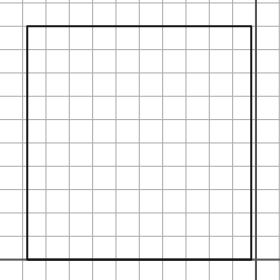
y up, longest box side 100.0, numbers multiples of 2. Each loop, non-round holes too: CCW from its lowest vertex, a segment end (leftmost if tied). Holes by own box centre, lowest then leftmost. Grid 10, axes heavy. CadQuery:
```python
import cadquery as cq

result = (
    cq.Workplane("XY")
    .moveTo(-98.0, 0.0)
    .lineTo(-2.0, 0.0)
    .lineTo(-2.0, 100.0)
    .lineTo(-98.0, 100.0)
    .close()
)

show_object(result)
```